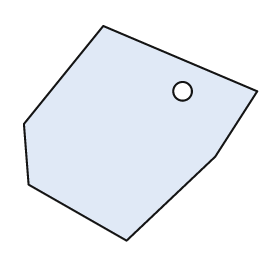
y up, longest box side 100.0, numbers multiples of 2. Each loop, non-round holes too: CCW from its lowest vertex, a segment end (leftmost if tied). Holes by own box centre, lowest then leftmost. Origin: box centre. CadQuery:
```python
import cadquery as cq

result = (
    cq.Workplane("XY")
    .moveTo(-6.0, -46.0)
    .lineTo(32.0, -10.0)
    .lineTo(50.0, 18.0)
    .lineTo(-16.0, 46.0)
    .lineTo(-50.0, 4.0)
    .lineTo(-48.0, -22.0)
    .close()
    .moveTo(18.0, 18.0)
    .circle(4.0)
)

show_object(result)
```